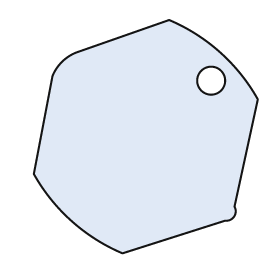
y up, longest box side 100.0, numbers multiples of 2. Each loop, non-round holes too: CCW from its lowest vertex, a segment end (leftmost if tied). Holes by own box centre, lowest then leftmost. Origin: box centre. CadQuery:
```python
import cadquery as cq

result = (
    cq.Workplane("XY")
    .moveTo(-10.0, -50.0)
    .lineTo(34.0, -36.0)
    .threePointArc((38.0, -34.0), (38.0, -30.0))
    .lineTo(48.0, 16.0)
    .threePointArc((32.0, 36.0), (10.0, 50.0))
    .lineTo(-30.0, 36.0)
    .threePointArc((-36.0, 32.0), (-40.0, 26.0))
    .lineTo(-48.0, -16.0)
    .threePointArc((-32.0, -36.0), (-10.0, -50.0))
    .close()
    .moveTo(28.0, 24.0)
    .circle(6.0)
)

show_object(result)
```